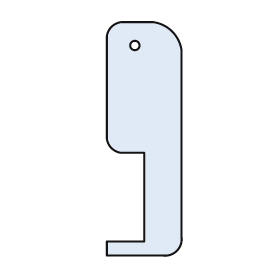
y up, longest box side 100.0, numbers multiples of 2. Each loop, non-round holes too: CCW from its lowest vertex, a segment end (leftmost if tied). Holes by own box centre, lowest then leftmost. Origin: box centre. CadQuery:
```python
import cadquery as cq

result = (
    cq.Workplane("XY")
    .moveTo(-16.0, -50.0)
    .lineTo(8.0, -50.0)
    .threePointArc((14.0, -48.0), (16.0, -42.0))
    .lineTo(16.0, 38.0)
    .threePointArc((12.0, 46.0), (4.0, 50.0))
    .lineTo(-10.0, 50.0)
    .threePointArc((-14.0, 48.0), (-16.0, 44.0))
    .lineTo(-16.0, 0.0)
    .threePointArc((-14.0, -4.0), (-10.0, -6.0))
    .lineTo(0.0, -6.0)
    .lineTo(0.0, -44.0)
    .lineTo(-16.0, -44.0)
    .close()
    .moveTo(-4.0, 40.0)
    .circle(2.0)
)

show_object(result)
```